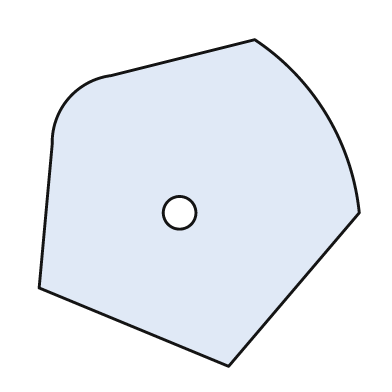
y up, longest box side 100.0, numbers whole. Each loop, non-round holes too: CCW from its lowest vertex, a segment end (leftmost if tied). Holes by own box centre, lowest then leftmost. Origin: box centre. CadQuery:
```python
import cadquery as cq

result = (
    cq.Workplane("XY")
    .moveTo(9.0, -50.0)
    .lineTo(49.0, -3.0)
    .threePointArc((39.0, 27.0), (17.0, 50.0))
    .lineTo(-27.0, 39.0)
    .threePointArc((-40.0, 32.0), (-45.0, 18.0))
    .lineTo(-49.0, -26.0)
    .close()
    .moveTo(-6.0, -3.0)
    .circle(5.0)
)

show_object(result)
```